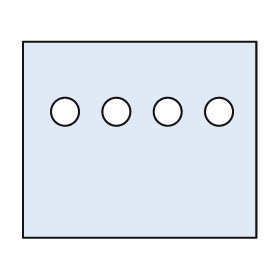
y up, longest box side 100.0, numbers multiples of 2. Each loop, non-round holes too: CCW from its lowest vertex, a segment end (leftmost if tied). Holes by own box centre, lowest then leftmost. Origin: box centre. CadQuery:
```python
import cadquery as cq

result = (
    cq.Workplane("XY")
    .moveTo(-50.0, -42.0)
    .lineTo(50.0, -42.0)
    .lineTo(50.0, 42.0)
    .lineTo(-50.0, 42.0)
    .close()
    .moveTo(-32.0, 12.0)
    .circle(6.0)
    .moveTo(-10.0, 12.0)
    .circle(6.0)
    .moveTo(12.0, 12.0)
    .circle(6.0)
    .moveTo(34.0, 12.0)
    .circle(6.0)
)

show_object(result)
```